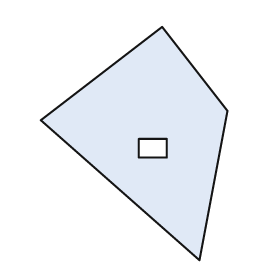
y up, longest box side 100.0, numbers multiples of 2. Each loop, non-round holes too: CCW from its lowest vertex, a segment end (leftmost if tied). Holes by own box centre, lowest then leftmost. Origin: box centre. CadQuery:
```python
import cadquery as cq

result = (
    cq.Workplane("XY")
    .moveTo(28.0, -50.0)
    .lineTo(40.0, 14.0)
    .lineTo(12.0, 50.0)
    .lineTo(-40.0, 10.0)
    .close()
    .moveTo(2.0, -6.0)
    .lineTo(14.0, -6.0)
    .lineTo(14.0, 2.0)
    .lineTo(2.0, 2.0)
    .close()
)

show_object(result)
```